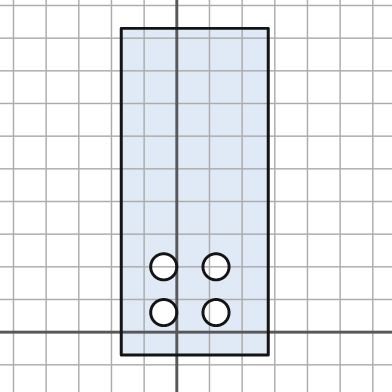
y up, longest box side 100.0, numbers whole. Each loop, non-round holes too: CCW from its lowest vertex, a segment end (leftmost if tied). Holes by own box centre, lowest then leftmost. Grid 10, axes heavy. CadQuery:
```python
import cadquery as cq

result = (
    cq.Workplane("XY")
    .moveTo(-17.0, -7.0)
    .lineTo(28.0, -7.0)
    .lineTo(28.0, 93.0)
    .lineTo(-17.0, 93.0)
    .close()
    .moveTo(-4.0, 6.0)
    .circle(4.0)
    .moveTo(12.0, 6.0)
    .circle(4.0)
    .moveTo(-4.0, 20.0)
    .circle(4.0)
    .moveTo(12.0, 20.0)
    .circle(4.0)
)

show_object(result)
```